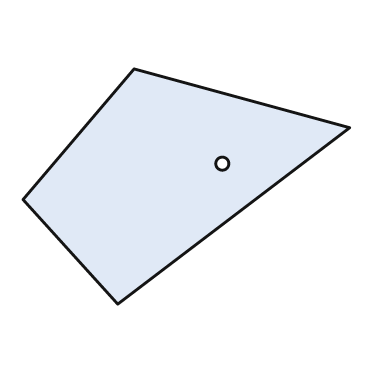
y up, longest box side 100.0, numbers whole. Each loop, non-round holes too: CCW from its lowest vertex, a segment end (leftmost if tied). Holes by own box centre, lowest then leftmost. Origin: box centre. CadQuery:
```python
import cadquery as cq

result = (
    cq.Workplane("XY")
    .moveTo(-21.0, -36.0)
    .lineTo(50.0, 18.0)
    .lineTo(-16.0, 36.0)
    .lineTo(-50.0, -4.0)
    .close()
    .moveTo(11.0, 7.0)
    .circle(2.0)
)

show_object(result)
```